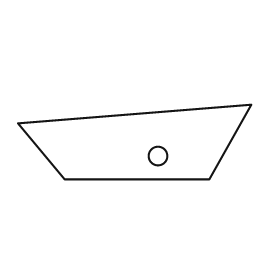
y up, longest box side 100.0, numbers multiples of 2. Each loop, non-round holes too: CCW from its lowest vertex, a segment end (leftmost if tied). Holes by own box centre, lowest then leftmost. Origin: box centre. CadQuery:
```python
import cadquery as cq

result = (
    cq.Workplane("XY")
    .moveTo(-30.0, -16.0)
    .lineTo(32.0, -16.0)
    .lineTo(50.0, 16.0)
    .lineTo(-50.0, 8.0)
    .close()
    .moveTo(10.0, -6.0)
    .circle(4.0)
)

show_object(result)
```